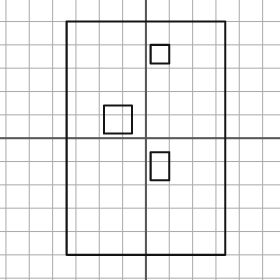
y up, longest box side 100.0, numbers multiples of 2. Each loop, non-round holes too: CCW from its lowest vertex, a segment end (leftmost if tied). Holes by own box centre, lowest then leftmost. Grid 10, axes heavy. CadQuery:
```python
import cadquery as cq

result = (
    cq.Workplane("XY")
    .moveTo(-34.0, -50.0)
    .lineTo(34.0, -50.0)
    .lineTo(34.0, 50.0)
    .lineTo(-34.0, 50.0)
    .close()
    .moveTo(2.0, -18.0)
    .lineTo(10.0, -18.0)
    .lineTo(10.0, -6.0)
    .lineTo(2.0, -6.0)
    .close()
    .moveTo(-18.0, 2.0)
    .lineTo(-6.0, 2.0)
    .lineTo(-6.0, 14.0)
    .lineTo(-18.0, 14.0)
    .close()
    .moveTo(2.0, 32.0)
    .lineTo(10.0, 32.0)
    .lineTo(10.0, 40.0)
    .lineTo(2.0, 40.0)
    .close()
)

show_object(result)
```